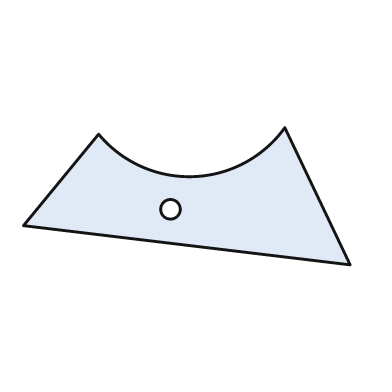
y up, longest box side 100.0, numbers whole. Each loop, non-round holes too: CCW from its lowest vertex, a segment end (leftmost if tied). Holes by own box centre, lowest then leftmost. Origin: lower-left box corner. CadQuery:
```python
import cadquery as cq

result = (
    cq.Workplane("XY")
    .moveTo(100.0, 0.0)
    .lineTo(80.0, 42.0)
    .threePointArc((52.0, 27.0), (23.0, 40.0))
    .lineTo(0.0, 12.0)
    .close()
    .moveTo(45.0, 17.0)
    .circle(3.0)
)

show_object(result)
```